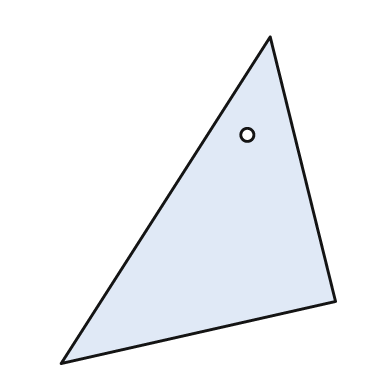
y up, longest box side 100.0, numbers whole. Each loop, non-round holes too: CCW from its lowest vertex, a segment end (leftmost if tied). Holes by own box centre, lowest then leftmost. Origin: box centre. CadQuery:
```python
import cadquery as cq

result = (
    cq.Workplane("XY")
    .moveTo(-42.0, -50.0)
    .lineTo(42.0, -31.0)
    .lineTo(22.0, 50.0)
    .close()
    .moveTo(15.0, 20.0)
    .circle(2.0)
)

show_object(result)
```